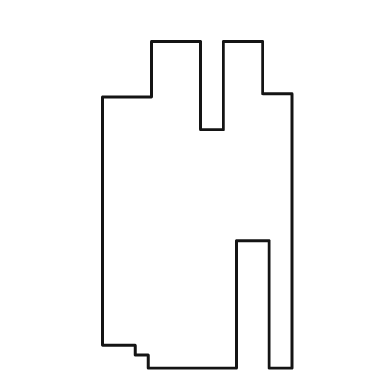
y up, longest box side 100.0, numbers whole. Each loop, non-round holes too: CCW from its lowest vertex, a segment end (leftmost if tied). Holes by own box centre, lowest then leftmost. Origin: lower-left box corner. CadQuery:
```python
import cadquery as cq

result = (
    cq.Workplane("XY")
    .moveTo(14.0, 0.0)
    .lineTo(41.0, 0.0)
    .lineTo(41.0, 39.0)
    .lineTo(51.0, 39.0)
    .lineTo(51.0, 0.0)
    .lineTo(58.0, 0.0)
    .lineTo(58.0, 84.0)
    .lineTo(49.0, 84.0)
    .lineTo(49.0, 100.0)
    .lineTo(37.0, 100.0)
    .lineTo(37.0, 73.0)
    .lineTo(30.0, 73.0)
    .lineTo(30.0, 100.0)
    .lineTo(15.0, 100.0)
    .lineTo(15.0, 83.0)
    .lineTo(0.0, 83.0)
    .lineTo(0.0, 7.0)
    .lineTo(10.0, 7.0)
    .lineTo(10.0, 4.0)
    .lineTo(14.0, 4.0)
    .close()
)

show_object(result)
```